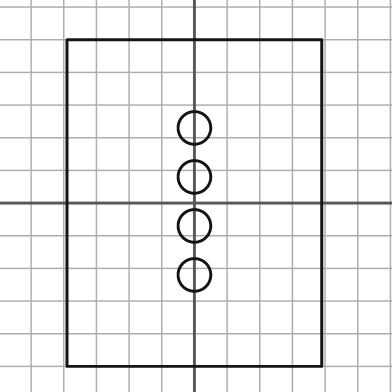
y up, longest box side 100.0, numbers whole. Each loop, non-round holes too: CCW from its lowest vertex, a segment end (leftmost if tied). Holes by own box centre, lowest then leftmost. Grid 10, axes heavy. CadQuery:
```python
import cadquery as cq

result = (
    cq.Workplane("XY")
    .moveTo(-39.0, -50.0)
    .lineTo(39.0, -50.0)
    .lineTo(39.0, 50.0)
    .lineTo(-39.0, 50.0)
    .close()
    .moveTo(0.0, -22.0)
    .circle(5.0)
    .moveTo(0.0, -7.0)
    .circle(5.0)
    .moveTo(0.0, 8.0)
    .circle(5.0)
    .moveTo(0.0, 23.0)
    .circle(5.0)
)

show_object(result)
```